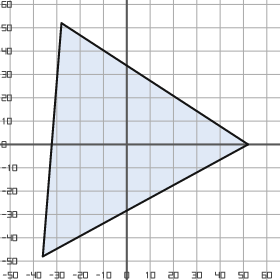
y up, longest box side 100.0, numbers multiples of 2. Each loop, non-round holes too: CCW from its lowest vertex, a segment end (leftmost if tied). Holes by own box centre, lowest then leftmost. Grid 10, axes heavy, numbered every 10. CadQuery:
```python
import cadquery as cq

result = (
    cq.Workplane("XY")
    .moveTo(-36.0, -48.0)
    .lineTo(52.0, 0.0)
    .lineTo(-28.0, 52.0)
    .close()
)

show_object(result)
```